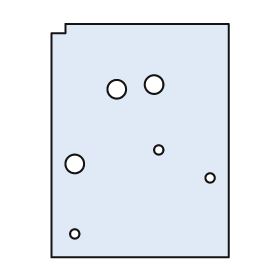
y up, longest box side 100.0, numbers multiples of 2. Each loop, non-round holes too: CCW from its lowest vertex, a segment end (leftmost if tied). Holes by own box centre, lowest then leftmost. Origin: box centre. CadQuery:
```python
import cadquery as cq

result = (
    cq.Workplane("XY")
    .moveTo(-38.0, -50.0)
    .lineTo(38.0, -50.0)
    .lineTo(38.0, 50.0)
    .lineTo(-32.0, 50.0)
    .lineTo(-32.0, 46.0)
    .lineTo(-38.0, 46.0)
    .close()
    .moveTo(-28.0, -40.0)
    .circle(2.0)
    .moveTo(30.0, -16.0)
    .circle(2.0)
    .moveTo(-28.0, -10.0)
    .circle(4.0)
    .moveTo(8.0, -4.0)
    .circle(2.0)
    .moveTo(-10.0, 22.0)
    .circle(4.0)
    .moveTo(6.0, 24.0)
    .circle(4.0)
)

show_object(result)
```